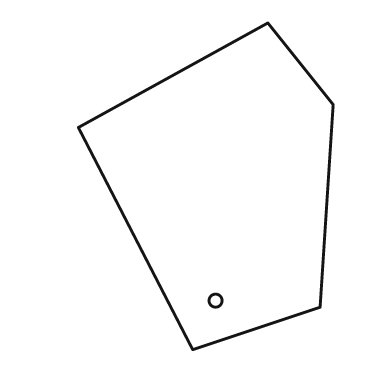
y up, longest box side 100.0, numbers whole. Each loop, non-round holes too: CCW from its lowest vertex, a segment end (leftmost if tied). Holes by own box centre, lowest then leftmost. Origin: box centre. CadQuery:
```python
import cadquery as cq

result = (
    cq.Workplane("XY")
    .moveTo(-4.0, -50.0)
    .lineTo(35.0, -37.0)
    .lineTo(39.0, 25.0)
    .lineTo(19.0, 50.0)
    .lineTo(-39.0, 18.0)
    .close()
    .moveTo(3.0, -35.0)
    .circle(2.0)
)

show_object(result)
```